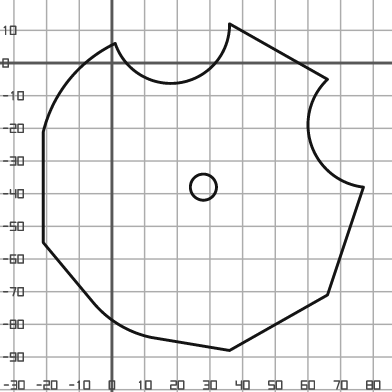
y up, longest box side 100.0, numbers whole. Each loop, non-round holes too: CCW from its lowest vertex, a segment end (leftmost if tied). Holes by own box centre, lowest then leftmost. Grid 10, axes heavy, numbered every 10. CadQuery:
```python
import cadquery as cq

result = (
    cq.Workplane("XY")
    .moveTo(36.0, -88.0)
    .lineTo(66.0, -71.0)
    .lineTo(77.0, -38.0)
    .threePointArc((61.0, -25.0), (66.0, -5.0))
    .lineTo(36.0, 12.0)
    .threePointArc((21.0, -6.0), (1.0, 6.0))
    .threePointArc((-13.0, -5.0), (-21.0, -21.0))
    .lineTo(-21.0, -55.0)
    .lineTo(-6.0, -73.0)
    .threePointArc((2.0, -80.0), (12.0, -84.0))
    .close()
    .moveTo(28.0, -38.0)
    .circle(4.0)
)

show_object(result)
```